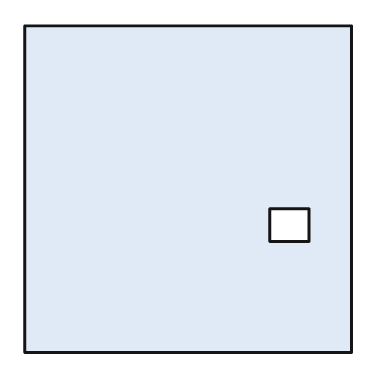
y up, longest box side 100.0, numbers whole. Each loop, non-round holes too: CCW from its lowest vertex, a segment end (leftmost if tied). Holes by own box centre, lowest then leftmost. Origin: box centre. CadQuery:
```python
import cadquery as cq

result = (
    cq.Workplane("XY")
    .moveTo(-50.0, -50.0)
    .lineTo(50.0, -50.0)
    .lineTo(50.0, 50.0)
    .lineTo(-50.0, 50.0)
    .close()
    .moveTo(25.0, -16.0)
    .lineTo(37.0, -16.0)
    .lineTo(37.0, -6.0)
    .lineTo(25.0, -6.0)
    .close()
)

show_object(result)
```